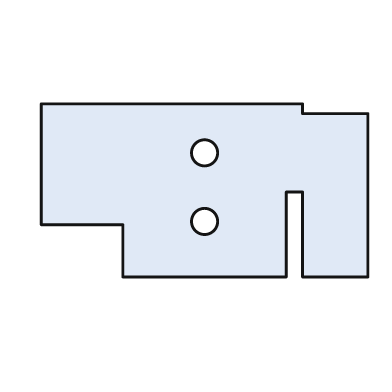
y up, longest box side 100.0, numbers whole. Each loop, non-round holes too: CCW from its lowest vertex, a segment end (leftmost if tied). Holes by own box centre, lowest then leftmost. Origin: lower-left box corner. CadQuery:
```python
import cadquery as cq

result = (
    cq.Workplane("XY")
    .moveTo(25.0, 0.0)
    .lineTo(75.0, 0.0)
    .lineTo(75.0, 26.0)
    .lineTo(80.0, 26.0)
    .lineTo(80.0, 0.0)
    .lineTo(100.0, 0.0)
    .lineTo(100.0, 50.0)
    .lineTo(80.0, 50.0)
    .lineTo(80.0, 53.0)
    .lineTo(0.0, 53.0)
    .lineTo(0.0, 16.0)
    .lineTo(25.0, 16.0)
    .close()
    .moveTo(50.0, 17.0)
    .circle(4.0)
    .moveTo(50.0, 38.0)
    .circle(4.0)
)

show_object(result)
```